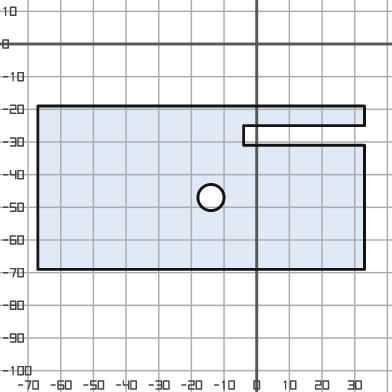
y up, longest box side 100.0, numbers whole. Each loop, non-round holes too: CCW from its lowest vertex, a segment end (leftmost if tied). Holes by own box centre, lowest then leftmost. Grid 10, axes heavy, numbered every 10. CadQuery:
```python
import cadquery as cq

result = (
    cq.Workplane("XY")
    .moveTo(-67.0, -69.0)
    .lineTo(33.0, -69.0)
    .lineTo(33.0, -31.0)
    .lineTo(-4.0, -31.0)
    .lineTo(-4.0, -25.0)
    .lineTo(33.0, -25.0)
    .lineTo(33.0, -19.0)
    .lineTo(-67.0, -19.0)
    .close()
    .moveTo(-14.0, -47.0)
    .circle(4.0)
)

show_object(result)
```